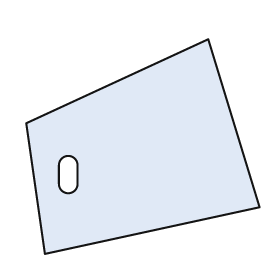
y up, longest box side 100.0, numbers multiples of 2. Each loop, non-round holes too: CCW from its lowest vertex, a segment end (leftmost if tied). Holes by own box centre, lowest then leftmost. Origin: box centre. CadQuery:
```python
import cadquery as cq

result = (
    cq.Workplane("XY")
    .moveTo(-42.0, -46.0)
    .lineTo(50.0, -26.0)
    .lineTo(28.0, 46.0)
    .lineTo(-50.0, 10.0)
    .close()
    .moveTo(-36.0, -16.0)
    .threePointArc((-32.0, -20.0), (-28.0, -16.0))
    .lineTo(-28.0, -8.0)
    .threePointArc((-32.0, -4.0), (-36.0, -8.0))
    .close()
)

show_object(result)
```